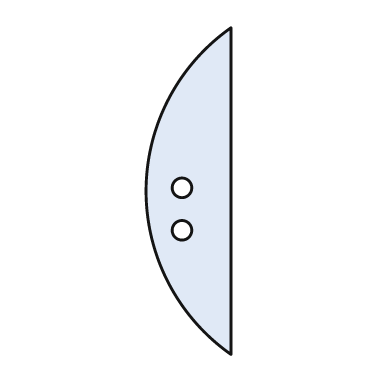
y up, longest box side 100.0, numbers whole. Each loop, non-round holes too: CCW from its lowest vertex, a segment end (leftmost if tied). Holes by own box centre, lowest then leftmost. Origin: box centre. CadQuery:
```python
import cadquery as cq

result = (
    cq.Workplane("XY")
    .moveTo(13.0, -50.0)
    .lineTo(13.0, 50.0)
    .threePointArc((-13.0, 0.0), (13.0, -50.0))
    .close()
    .moveTo(-2.0, -12.0)
    .circle(3.0)
    .moveTo(-2.0, 1.0)
    .circle(3.0)
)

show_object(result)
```